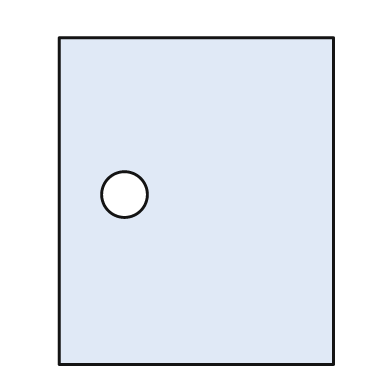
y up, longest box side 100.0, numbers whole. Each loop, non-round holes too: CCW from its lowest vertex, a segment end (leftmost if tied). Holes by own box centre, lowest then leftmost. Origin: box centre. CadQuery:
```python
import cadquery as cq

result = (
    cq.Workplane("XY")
    .moveTo(-42.0, -50.0)
    .lineTo(42.0, -50.0)
    .lineTo(42.0, 50.0)
    .lineTo(-42.0, 50.0)
    .close()
    .moveTo(-22.0, 2.0)
    .circle(7.0)
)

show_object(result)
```